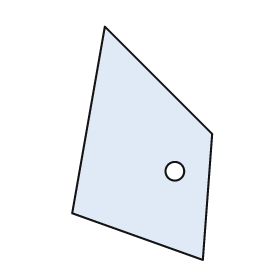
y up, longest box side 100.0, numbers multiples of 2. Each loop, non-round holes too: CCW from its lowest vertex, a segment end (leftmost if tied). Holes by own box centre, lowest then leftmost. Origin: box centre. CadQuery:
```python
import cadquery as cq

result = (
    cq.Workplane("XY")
    .moveTo(26.0, -50.0)
    .lineTo(30.0, 4.0)
    .lineTo(-16.0, 50.0)
    .lineTo(-30.0, -30.0)
    .close()
    .moveTo(14.0, -12.0)
    .circle(4.0)
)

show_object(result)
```